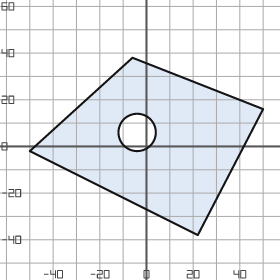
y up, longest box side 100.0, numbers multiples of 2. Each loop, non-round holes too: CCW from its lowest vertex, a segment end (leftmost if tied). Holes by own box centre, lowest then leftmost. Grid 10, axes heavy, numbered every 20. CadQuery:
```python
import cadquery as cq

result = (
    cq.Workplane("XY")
    .moveTo(22.0, -38.0)
    .lineTo(50.0, 16.0)
    .lineTo(-6.0, 38.0)
    .lineTo(-50.0, -2.0)
    .close()
    .moveTo(-4.0, 6.0)
    .circle(8.0)
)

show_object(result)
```